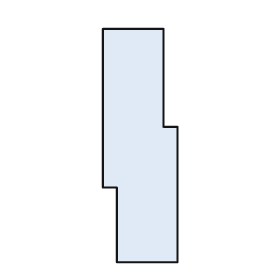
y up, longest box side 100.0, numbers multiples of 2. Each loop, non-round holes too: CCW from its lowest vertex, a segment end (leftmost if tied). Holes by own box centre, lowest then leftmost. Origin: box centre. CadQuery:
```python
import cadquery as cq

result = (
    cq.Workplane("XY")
    .moveTo(-10.0, -50.0)
    .lineTo(16.0, -50.0)
    .lineTo(16.0, 8.0)
    .lineTo(10.0, 8.0)
    .lineTo(10.0, 50.0)
    .lineTo(-16.0, 50.0)
    .lineTo(-16.0, -18.0)
    .lineTo(-10.0, -18.0)
    .close()
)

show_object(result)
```